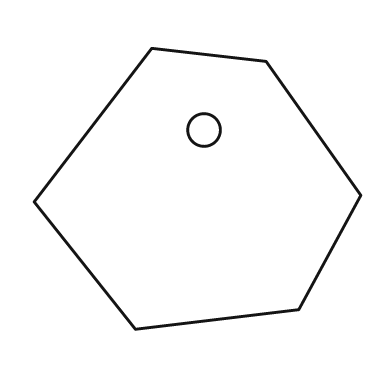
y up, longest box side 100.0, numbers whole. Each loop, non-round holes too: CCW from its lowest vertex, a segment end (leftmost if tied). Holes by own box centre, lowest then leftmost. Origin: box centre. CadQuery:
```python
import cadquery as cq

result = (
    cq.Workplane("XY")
    .moveTo(-19.0, -43.0)
    .lineTo(31.0, -37.0)
    .lineTo(50.0, -2.0)
    .lineTo(21.0, 39.0)
    .lineTo(-14.0, 43.0)
    .lineTo(-50.0, -4.0)
    .close()
    .moveTo(2.0, 18.0)
    .circle(5.0)
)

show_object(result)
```